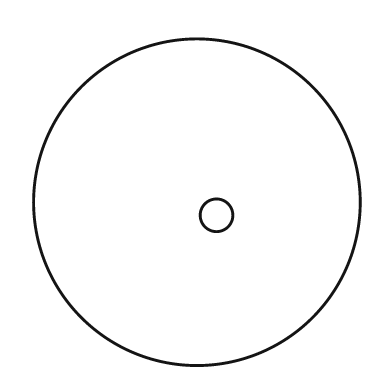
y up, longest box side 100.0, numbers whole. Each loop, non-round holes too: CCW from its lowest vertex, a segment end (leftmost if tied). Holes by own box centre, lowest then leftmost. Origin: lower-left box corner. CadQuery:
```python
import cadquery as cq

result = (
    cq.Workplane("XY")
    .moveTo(50.0, 50.0)
    .circle(50.0)
    .moveTo(56.0, 46.0)
    .circle(5.0)
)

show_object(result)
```